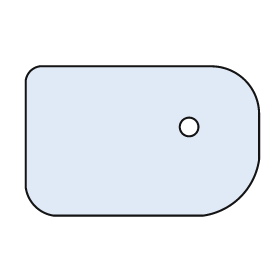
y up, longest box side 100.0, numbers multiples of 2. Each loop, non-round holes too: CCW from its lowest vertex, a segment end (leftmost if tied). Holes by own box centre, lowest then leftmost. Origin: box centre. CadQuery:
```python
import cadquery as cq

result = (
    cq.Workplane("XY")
    .moveTo(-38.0, -32.0)
    .lineTo(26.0, -32.0)
    .threePointArc((42.0, -24.0), (50.0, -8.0))
    .lineTo(50.0, 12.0)
    .threePointArc((44.0, 26.0), (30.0, 32.0))
    .lineTo(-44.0, 32.0)
    .threePointArc((-48.0, 30.0), (-50.0, 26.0))
    .lineTo(-50.0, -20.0)
    .threePointArc((-46.0, -28.0), (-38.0, -32.0))
    .close()
    .moveTo(20.0, 6.0)
    .circle(4.0)
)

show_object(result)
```